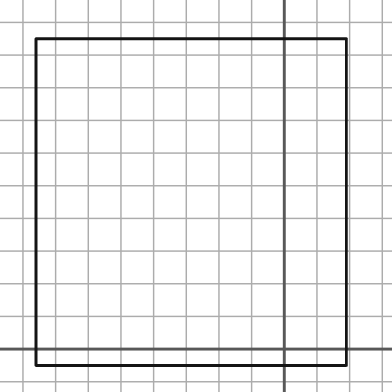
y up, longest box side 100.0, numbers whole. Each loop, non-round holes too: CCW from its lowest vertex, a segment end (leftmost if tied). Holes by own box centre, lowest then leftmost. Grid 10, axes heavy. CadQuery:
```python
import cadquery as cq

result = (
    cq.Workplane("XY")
    .moveTo(-76.0, -5.0)
    .lineTo(19.0, -5.0)
    .lineTo(19.0, 95.0)
    .lineTo(-76.0, 95.0)
    .close()
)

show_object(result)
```